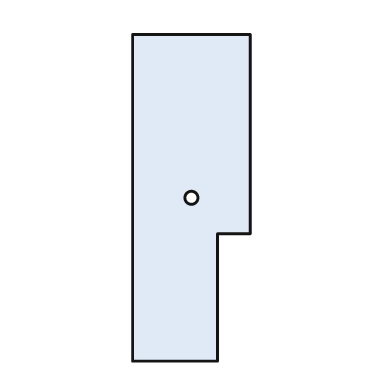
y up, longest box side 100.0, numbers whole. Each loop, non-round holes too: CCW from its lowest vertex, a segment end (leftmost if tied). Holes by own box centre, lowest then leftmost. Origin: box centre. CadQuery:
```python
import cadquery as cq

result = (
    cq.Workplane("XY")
    .moveTo(-18.0, -50.0)
    .lineTo(8.0, -50.0)
    .lineTo(8.0, -11.0)
    .lineTo(18.0, -11.0)
    .lineTo(18.0, 50.0)
    .lineTo(-18.0, 50.0)
    .close()
    .moveTo(0.0, 0.0)
    .circle(2.0)
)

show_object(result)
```